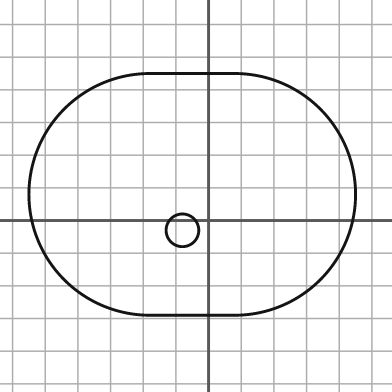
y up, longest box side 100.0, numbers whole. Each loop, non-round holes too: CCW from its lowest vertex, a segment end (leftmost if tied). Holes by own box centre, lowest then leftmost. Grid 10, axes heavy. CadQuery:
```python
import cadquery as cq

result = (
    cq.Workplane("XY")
    .moveTo(-18.0, -29.0)
    .lineTo(8.0, -29.0)
    .threePointArc((45.0, 8.0), (8.0, 45.0))
    .lineTo(-18.0, 45.0)
    .threePointArc((-55.0, 8.0), (-18.0, -29.0))
    .close()
    .moveTo(-8.0, -3.0)
    .circle(5.0)
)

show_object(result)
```